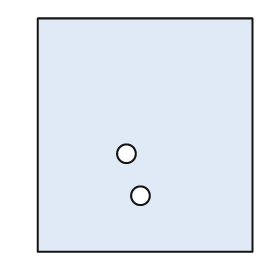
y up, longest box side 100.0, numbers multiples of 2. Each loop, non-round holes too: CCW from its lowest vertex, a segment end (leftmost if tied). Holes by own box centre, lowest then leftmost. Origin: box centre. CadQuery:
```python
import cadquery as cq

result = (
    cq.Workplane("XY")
    .moveTo(-46.0, -50.0)
    .lineTo(46.0, -50.0)
    .lineTo(46.0, 50.0)
    .lineTo(-46.0, 50.0)
    .close()
    .moveTo(-2.0, -26.0)
    .circle(4.0)
    .moveTo(-8.0, -8.0)
    .circle(4.0)
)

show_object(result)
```